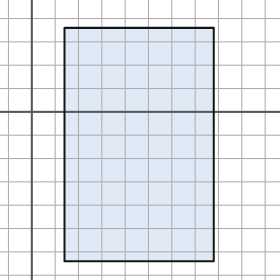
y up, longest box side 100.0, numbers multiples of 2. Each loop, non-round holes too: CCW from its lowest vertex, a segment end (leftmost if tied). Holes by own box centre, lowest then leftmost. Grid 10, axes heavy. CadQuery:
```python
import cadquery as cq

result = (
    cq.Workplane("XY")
    .moveTo(14.0, -64.0)
    .lineTo(78.0, -64.0)
    .lineTo(78.0, 36.0)
    .lineTo(14.0, 36.0)
    .close()
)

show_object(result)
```